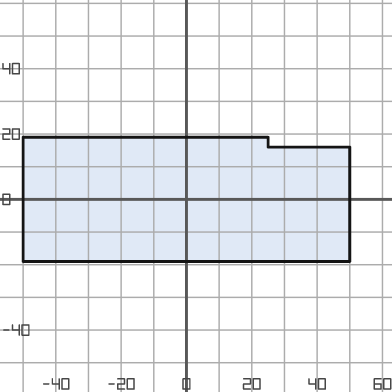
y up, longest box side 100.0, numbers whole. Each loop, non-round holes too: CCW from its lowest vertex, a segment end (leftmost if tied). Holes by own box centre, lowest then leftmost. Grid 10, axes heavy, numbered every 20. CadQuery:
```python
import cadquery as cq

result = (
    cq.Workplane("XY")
    .moveTo(-50.0, -19.0)
    .lineTo(50.0, -19.0)
    .lineTo(50.0, 16.0)
    .lineTo(25.0, 16.0)
    .lineTo(25.0, 19.0)
    .lineTo(-50.0, 19.0)
    .close()
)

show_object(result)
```